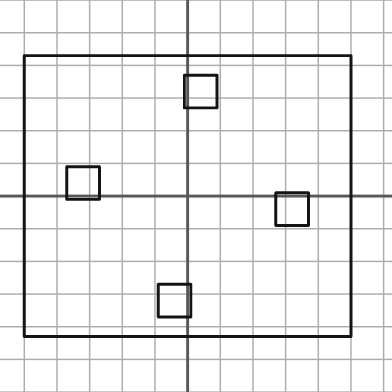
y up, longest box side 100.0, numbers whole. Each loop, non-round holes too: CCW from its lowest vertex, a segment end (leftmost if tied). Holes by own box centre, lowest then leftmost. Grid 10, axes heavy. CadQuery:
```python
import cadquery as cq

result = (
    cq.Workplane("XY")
    .moveTo(-50.0, -43.0)
    .lineTo(50.0, -43.0)
    .lineTo(50.0, 43.0)
    .lineTo(-50.0, 43.0)
    .close()
    .moveTo(-9.0, -37.0)
    .lineTo(1.0, -37.0)
    .lineTo(1.0, -27.0)
    .lineTo(-9.0, -27.0)
    .close()
    .moveTo(27.0, -9.0)
    .lineTo(37.0, -9.0)
    .lineTo(37.0, 1.0)
    .lineTo(27.0, 1.0)
    .close()
    .moveTo(-37.0, -1.0)
    .lineTo(-27.0, -1.0)
    .lineTo(-27.0, 9.0)
    .lineTo(-37.0, 9.0)
    .close()
    .moveTo(-1.0, 27.0)
    .lineTo(9.0, 27.0)
    .lineTo(9.0, 37.0)
    .lineTo(-1.0, 37.0)
    .close()
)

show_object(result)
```